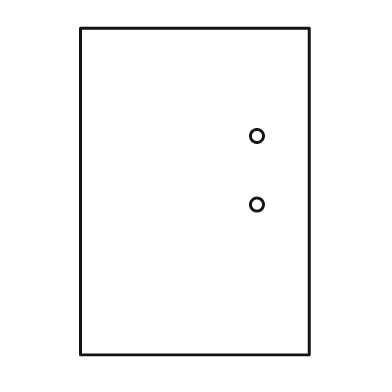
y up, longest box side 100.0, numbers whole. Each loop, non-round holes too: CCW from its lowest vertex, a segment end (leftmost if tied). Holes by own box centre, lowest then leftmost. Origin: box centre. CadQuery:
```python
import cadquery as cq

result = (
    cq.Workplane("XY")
    .moveTo(-35.0, -50.0)
    .lineTo(35.0, -50.0)
    .lineTo(35.0, 50.0)
    .lineTo(-35.0, 50.0)
    .close()
    .moveTo(19.0, -4.0)
    .circle(2.0)
    .moveTo(19.0, 17.0)
    .circle(2.0)
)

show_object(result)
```